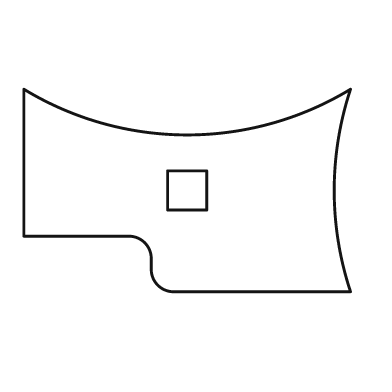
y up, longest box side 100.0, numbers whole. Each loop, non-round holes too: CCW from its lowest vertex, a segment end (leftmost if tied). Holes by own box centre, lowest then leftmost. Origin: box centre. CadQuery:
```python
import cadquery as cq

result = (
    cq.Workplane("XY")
    .moveTo(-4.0, -31.0)
    .lineTo(50.0, -31.0)
    .threePointArc((45.0, 0.0), (50.0, 31.0))
    .threePointArc((0.0, 17.0), (-50.0, 31.0))
    .lineTo(-50.0, -14.0)
    .lineTo(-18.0, -14.0)
    .threePointArc((-13.0, -16.0), (-11.0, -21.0))
    .lineTo(-11.0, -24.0)
    .threePointArc((-9.0, -29.0), (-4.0, -31.0))
    .close()
    .moveTo(-6.0, -6.0)
    .lineTo(6.0, -6.0)
    .lineTo(6.0, 6.0)
    .lineTo(-6.0, 6.0)
    .close()
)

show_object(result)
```